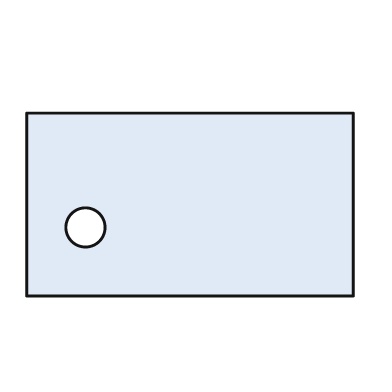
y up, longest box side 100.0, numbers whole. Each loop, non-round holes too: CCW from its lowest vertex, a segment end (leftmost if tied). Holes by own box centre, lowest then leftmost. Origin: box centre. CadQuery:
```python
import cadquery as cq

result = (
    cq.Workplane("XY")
    .moveTo(-50.0, -28.0)
    .lineTo(50.0, -28.0)
    .lineTo(50.0, 28.0)
    .lineTo(-50.0, 28.0)
    .close()
    .moveTo(-32.0, -7.0)
    .circle(6.0)
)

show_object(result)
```